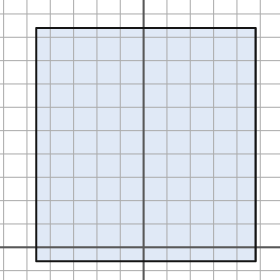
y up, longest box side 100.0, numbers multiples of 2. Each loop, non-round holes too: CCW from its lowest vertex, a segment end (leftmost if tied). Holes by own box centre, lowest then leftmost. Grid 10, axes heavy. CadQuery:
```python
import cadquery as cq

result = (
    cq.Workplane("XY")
    .moveTo(-46.0, -6.0)
    .lineTo(48.0, -6.0)
    .lineTo(48.0, 94.0)
    .lineTo(-46.0, 94.0)
    .close()
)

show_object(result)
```